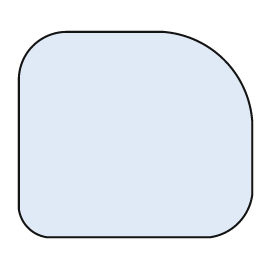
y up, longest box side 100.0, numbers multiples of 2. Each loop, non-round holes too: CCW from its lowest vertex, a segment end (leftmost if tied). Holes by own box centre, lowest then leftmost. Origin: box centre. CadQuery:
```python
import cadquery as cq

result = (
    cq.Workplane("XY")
    .moveTo(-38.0, -44.0)
    .lineTo(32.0, -44.0)
    .threePointArc((44.0, -38.0), (50.0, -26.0))
    .lineTo(50.0, 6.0)
    .threePointArc((38.0, 32.0), (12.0, 44.0))
    .lineTo(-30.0, 44.0)
    .threePointArc((-44.0, 38.0), (-50.0, 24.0))
    .lineTo(-50.0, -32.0)
    .threePointArc((-46.0, -40.0), (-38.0, -44.0))
    .close()
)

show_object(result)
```